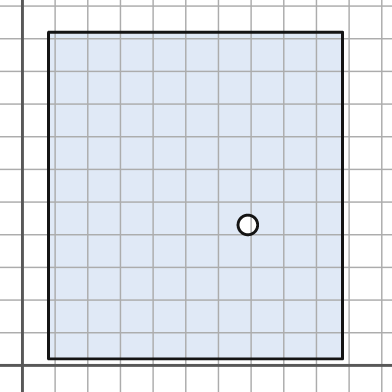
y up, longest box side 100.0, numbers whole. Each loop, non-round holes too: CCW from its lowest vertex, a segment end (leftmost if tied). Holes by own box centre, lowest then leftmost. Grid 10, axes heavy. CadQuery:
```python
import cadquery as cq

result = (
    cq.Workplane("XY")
    .moveTo(8.0, 2.0)
    .lineTo(98.0, 2.0)
    .lineTo(98.0, 102.0)
    .lineTo(8.0, 102.0)
    .close()
    .moveTo(69.0, 43.0)
    .circle(3.0)
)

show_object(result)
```